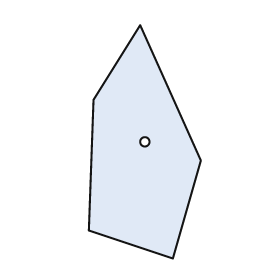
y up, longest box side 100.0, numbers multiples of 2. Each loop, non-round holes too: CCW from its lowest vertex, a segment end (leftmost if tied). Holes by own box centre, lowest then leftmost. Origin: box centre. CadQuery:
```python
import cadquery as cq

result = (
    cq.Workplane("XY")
    .moveTo(12.0, -50.0)
    .lineTo(24.0, -8.0)
    .lineTo(-2.0, 50.0)
    .lineTo(-22.0, 18.0)
    .lineTo(-24.0, -38.0)
    .close()
    .moveTo(0.0, 0.0)
    .circle(2.0)
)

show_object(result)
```